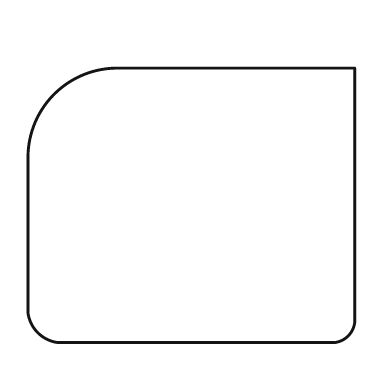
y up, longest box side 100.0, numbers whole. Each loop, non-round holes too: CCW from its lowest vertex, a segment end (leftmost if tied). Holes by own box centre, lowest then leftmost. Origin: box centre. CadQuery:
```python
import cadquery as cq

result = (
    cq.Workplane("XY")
    .moveTo(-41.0, -42.0)
    .lineTo(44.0, -42.0)
    .threePointArc((48.0, -40.0), (50.0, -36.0))
    .lineTo(50.0, 42.0)
    .lineTo(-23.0, 42.0)
    .threePointArc((-42.0, 34.0), (-50.0, 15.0))
    .lineTo(-50.0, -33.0)
    .threePointArc((-47.0, -39.0), (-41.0, -42.0))
    .close()
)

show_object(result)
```